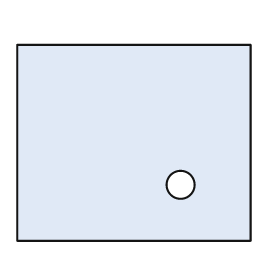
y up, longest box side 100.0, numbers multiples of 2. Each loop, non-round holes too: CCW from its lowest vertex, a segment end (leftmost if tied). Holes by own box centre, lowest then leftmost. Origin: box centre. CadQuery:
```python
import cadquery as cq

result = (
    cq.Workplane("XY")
    .moveTo(-50.0, -42.0)
    .lineTo(50.0, -42.0)
    .lineTo(50.0, 42.0)
    .lineTo(-50.0, 42.0)
    .close()
    .moveTo(20.0, -18.0)
    .circle(6.0)
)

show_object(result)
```